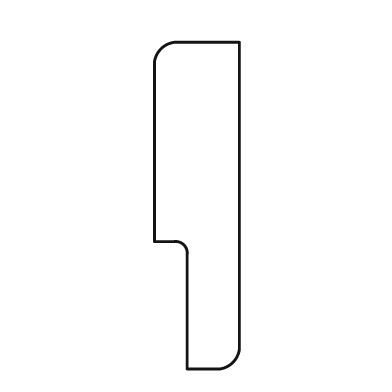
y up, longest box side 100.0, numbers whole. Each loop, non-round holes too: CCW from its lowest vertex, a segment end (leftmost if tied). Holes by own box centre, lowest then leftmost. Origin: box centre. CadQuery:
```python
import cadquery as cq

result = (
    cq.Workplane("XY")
    .moveTo(-3.0, -50.0)
    .lineTo(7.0, -50.0)
    .threePointArc((11.0, -48.0), (13.0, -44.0))
    .lineTo(13.0, 50.0)
    .lineTo(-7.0, 50.0)
    .threePointArc((-11.0, 48.0), (-13.0, 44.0))
    .lineTo(-13.0, -11.0)
    .lineTo(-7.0, -11.0)
    .threePointArc((-4.0, -12.0), (-3.0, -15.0))
    .close()
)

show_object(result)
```